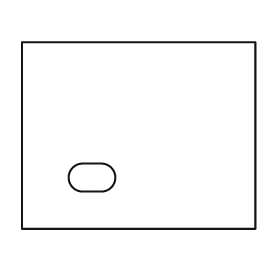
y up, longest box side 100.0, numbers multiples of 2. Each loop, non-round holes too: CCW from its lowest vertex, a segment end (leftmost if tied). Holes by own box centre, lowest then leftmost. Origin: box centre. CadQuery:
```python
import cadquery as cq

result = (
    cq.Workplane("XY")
    .moveTo(-50.0, -40.0)
    .lineTo(50.0, -40.0)
    .lineTo(50.0, 40.0)
    .lineTo(-50.0, 40.0)
    .close()
    .moveTo(-24.0, -24.0)
    .lineTo(-16.0, -24.0)
    .threePointArc((-10.0, -18.0), (-16.0, -12.0))
    .lineTo(-24.0, -12.0)
    .threePointArc((-30.0, -18.0), (-24.0, -24.0))
    .close()
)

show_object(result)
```